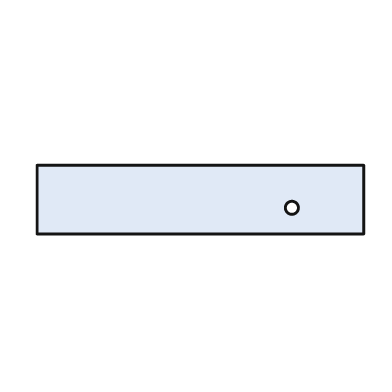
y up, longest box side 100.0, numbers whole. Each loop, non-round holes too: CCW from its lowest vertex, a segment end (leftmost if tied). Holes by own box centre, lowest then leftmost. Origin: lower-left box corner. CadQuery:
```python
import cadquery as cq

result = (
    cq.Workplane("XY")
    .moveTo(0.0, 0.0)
    .lineTo(100.0, 0.0)
    .lineTo(100.0, 21.0)
    .lineTo(0.0, 21.0)
    .close()
    .moveTo(78.0, 8.0)
    .circle(2.0)
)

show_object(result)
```